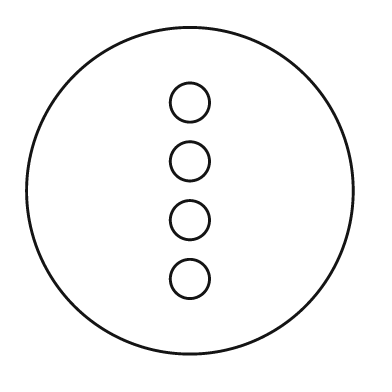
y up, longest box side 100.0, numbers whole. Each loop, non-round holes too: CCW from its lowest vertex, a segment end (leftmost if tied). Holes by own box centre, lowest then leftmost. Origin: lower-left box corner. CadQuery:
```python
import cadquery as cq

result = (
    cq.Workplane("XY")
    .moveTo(50.0, 50.0)
    .circle(50.0)
    .moveTo(50.0, 23.0)
    .circle(6.0)
    .moveTo(50.0, 41.0)
    .circle(6.0)
    .moveTo(50.0, 59.0)
    .circle(6.0)
    .moveTo(50.0, 77.0)
    .circle(6.0)
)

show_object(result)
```